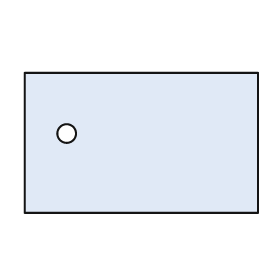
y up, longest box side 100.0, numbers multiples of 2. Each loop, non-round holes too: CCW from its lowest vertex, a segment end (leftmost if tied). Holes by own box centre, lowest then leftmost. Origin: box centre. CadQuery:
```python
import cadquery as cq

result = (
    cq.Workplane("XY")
    .moveTo(-50.0, -30.0)
    .lineTo(50.0, -30.0)
    .lineTo(50.0, 30.0)
    .lineTo(-50.0, 30.0)
    .close()
    .moveTo(-32.0, 4.0)
    .circle(4.0)
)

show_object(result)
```